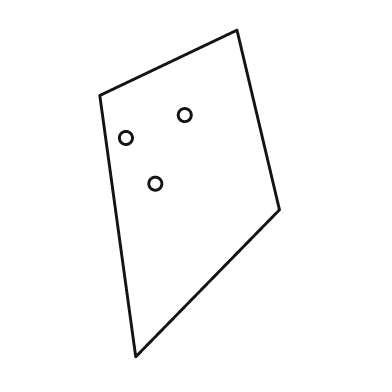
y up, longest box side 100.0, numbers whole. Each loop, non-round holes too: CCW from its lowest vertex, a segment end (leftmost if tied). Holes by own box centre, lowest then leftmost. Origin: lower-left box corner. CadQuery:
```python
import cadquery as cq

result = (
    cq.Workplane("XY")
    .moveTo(11.0, 0.0)
    .lineTo(55.0, 45.0)
    .lineTo(42.0, 100.0)
    .lineTo(0.0, 80.0)
    .close()
    .moveTo(17.0, 53.0)
    .circle(2.0)
    .moveTo(8.0, 67.0)
    .circle(2.0)
    .moveTo(26.0, 74.0)
    .circle(2.0)
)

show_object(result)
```